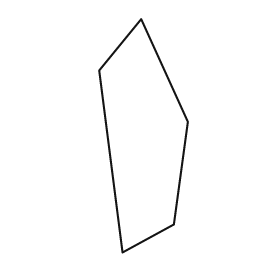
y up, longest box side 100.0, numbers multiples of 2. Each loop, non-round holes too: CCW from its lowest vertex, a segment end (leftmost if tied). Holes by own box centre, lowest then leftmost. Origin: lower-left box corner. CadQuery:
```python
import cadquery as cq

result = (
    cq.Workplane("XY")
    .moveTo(10.0, 0.0)
    .lineTo(32.0, 12.0)
    .lineTo(38.0, 56.0)
    .lineTo(18.0, 100.0)
    .lineTo(0.0, 78.0)
    .close()
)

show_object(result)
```